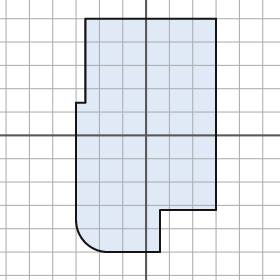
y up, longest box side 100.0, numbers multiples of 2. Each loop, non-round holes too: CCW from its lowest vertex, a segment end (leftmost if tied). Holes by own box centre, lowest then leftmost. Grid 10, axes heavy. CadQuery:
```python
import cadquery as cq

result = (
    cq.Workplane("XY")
    .moveTo(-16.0, -50.0)
    .lineTo(6.0, -50.0)
    .lineTo(6.0, -32.0)
    .lineTo(30.0, -32.0)
    .lineTo(30.0, 50.0)
    .lineTo(-26.0, 50.0)
    .lineTo(-26.0, 14.0)
    .lineTo(-30.0, 14.0)
    .lineTo(-30.0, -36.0)
    .threePointArc((-26.0, -46.0), (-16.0, -50.0))
    .close()
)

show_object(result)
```